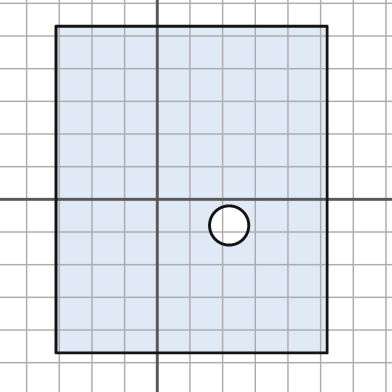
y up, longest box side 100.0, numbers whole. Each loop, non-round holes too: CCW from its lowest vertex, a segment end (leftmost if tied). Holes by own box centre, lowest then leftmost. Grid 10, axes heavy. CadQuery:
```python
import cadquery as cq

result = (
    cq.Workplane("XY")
    .moveTo(-31.0, -47.0)
    .lineTo(52.0, -47.0)
    .lineTo(52.0, 53.0)
    .lineTo(-31.0, 53.0)
    .close()
    .moveTo(22.0, -8.0)
    .circle(6.0)
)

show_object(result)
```